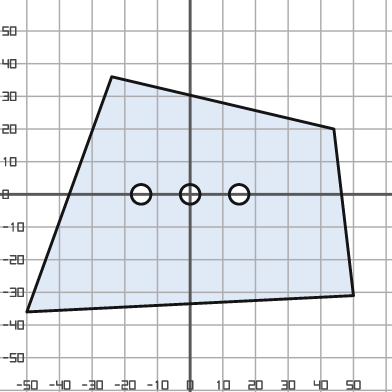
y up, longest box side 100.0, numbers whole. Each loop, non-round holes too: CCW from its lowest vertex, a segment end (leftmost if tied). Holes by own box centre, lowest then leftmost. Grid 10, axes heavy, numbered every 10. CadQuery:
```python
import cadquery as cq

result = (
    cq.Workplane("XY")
    .moveTo(-50.0, -36.0)
    .lineTo(50.0, -31.0)
    .lineTo(44.0, 20.0)
    .lineTo(-24.0, 36.0)
    .close()
    .moveTo(-15.0, 0.0)
    .circle(3.0)
    .moveTo(0.0, 0.0)
    .circle(3.0)
    .moveTo(15.0, 0.0)
    .circle(3.0)
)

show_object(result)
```